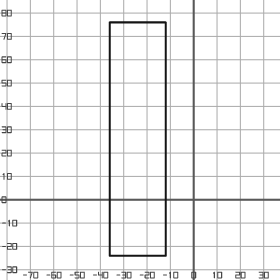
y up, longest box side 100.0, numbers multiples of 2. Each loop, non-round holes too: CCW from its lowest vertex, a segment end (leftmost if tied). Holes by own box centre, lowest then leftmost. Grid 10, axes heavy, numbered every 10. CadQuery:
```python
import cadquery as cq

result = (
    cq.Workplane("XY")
    .moveTo(-36.0, -24.0)
    .lineTo(-12.0, -24.0)
    .lineTo(-12.0, 76.0)
    .lineTo(-36.0, 76.0)
    .close()
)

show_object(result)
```